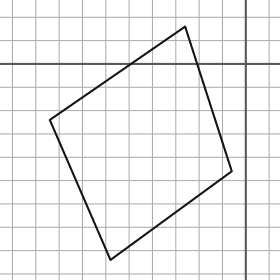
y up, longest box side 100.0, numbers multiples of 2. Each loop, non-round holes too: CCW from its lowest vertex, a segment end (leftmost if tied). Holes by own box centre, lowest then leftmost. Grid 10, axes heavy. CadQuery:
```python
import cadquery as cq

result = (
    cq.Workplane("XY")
    .moveTo(-58.0, -84.0)
    .lineTo(-6.0, -46.0)
    .lineTo(-26.0, 16.0)
    .lineTo(-84.0, -24.0)
    .close()
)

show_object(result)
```